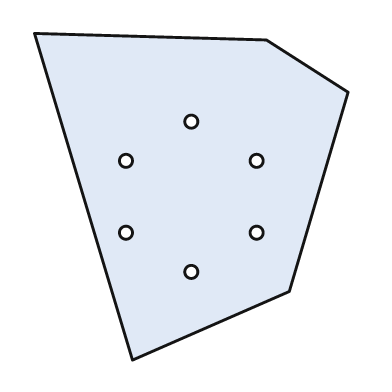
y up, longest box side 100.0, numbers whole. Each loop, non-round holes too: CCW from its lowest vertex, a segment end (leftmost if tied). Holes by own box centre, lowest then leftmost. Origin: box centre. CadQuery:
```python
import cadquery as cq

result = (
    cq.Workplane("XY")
    .moveTo(-18.0, -50.0)
    .lineTo(30.0, -29.0)
    .lineTo(48.0, 32.0)
    .lineTo(23.0, 48.0)
    .lineTo(-48.0, 50.0)
    .close()
    .moveTo(0.0, -23.0)
    .circle(2.0)
    .moveTo(-20.0, -11.0)
    .circle(2.0)
    .moveTo(20.0, -11.0)
    .circle(2.0)
    .moveTo(-20.0, 11.0)
    .circle(2.0)
    .moveTo(20.0, 11.0)
    .circle(2.0)
    .moveTo(0.0, 23.0)
    .circle(2.0)
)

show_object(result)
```